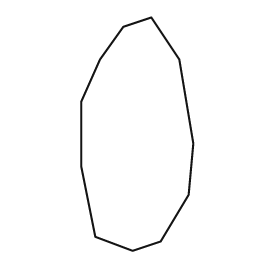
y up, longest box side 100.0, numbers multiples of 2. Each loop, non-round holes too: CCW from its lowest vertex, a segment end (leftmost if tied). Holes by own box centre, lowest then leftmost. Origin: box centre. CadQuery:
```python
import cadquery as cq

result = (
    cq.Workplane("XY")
    .moveTo(-2.0, -50.0)
    .lineTo(10.0, -46.0)
    .lineTo(22.0, -26.0)
    .lineTo(24.0, -4.0)
    .lineTo(18.0, 32.0)
    .lineTo(6.0, 50.0)
    .lineTo(-6.0, 46.0)
    .lineTo(-16.0, 32.0)
    .lineTo(-24.0, 14.0)
    .lineTo(-24.0, -14.0)
    .lineTo(-18.0, -44.0)
    .close()
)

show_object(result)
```